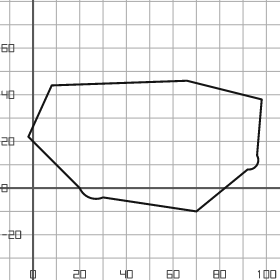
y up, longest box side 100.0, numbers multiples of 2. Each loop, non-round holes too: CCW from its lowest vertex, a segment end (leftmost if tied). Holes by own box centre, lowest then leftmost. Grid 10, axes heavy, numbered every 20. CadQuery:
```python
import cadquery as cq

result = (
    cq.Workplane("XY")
    .moveTo(70.0, -10.0)
    .lineTo(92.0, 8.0)
    .threePointArc((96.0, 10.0), (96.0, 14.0))
    .lineTo(98.0, 38.0)
    .lineTo(66.0, 46.0)
    .lineTo(8.0, 44.0)
    .lineTo(-2.0, 22.0)
    .lineTo(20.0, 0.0)
    .threePointArc((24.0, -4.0), (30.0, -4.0))
    .close()
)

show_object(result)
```